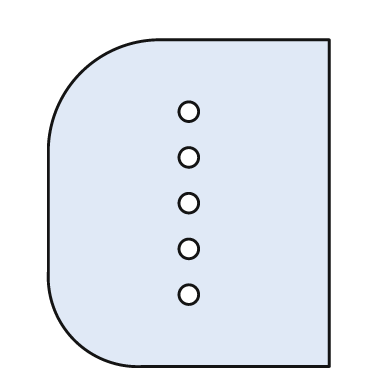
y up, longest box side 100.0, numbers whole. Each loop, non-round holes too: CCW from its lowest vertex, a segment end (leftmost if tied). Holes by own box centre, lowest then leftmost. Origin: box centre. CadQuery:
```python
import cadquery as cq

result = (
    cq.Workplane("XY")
    .moveTo(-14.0, -50.0)
    .lineTo(43.0, -50.0)
    .lineTo(43.0, 50.0)
    .lineTo(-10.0, 50.0)
    .threePointArc((-33.0, 40.0), (-43.0, 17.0))
    .lineTo(-43.0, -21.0)
    .threePointArc((-35.0, -42.0), (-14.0, -50.0))
    .close()
    .moveTo(0.0, -28.0)
    .circle(3.0)
    .moveTo(0.0, -14.0)
    .circle(3.0)
    .moveTo(0.0, 0.0)
    .circle(3.0)
    .moveTo(0.0, 14.0)
    .circle(3.0)
    .moveTo(0.0, 28.0)
    .circle(3.0)
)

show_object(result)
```